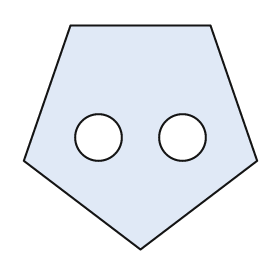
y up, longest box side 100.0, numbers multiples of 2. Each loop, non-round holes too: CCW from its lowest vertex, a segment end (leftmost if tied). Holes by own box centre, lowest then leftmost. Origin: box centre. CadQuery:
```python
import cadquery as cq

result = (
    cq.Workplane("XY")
    .moveTo(0.0, -48.0)
    .lineTo(50.0, -10.0)
    .lineTo(30.0, 48.0)
    .lineTo(-30.0, 48.0)
    .lineTo(-50.0, -10.0)
    .close()
    .moveTo(-18.0, 0.0)
    .circle(10.0)
    .moveTo(18.0, 0.0)
    .circle(10.0)
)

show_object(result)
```